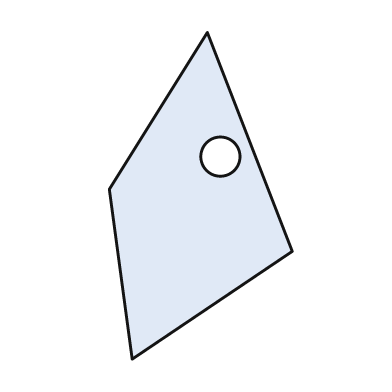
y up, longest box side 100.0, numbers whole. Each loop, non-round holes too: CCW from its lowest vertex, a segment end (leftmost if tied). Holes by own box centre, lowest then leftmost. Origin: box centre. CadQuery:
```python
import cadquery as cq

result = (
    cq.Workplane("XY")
    .moveTo(-21.0, -50.0)
    .lineTo(28.0, -17.0)
    .lineTo(2.0, 50.0)
    .lineTo(-28.0, 2.0)
    .close()
    .moveTo(6.0, 12.0)
    .circle(6.0)
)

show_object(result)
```